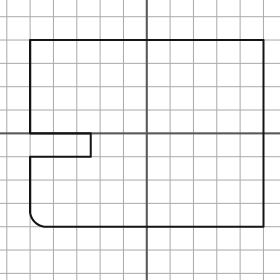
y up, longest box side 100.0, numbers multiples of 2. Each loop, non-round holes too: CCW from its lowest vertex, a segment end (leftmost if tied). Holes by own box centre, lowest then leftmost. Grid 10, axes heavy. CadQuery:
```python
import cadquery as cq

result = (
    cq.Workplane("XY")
    .moveTo(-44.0, -40.0)
    .lineTo(50.0, -40.0)
    .lineTo(50.0, 40.0)
    .lineTo(-50.0, 40.0)
    .lineTo(-50.0, 0.0)
    .lineTo(-24.0, 0.0)
    .lineTo(-24.0, -10.0)
    .lineTo(-50.0, -10.0)
    .lineTo(-50.0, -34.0)
    .threePointArc((-48.0, -38.0), (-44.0, -40.0))
    .close()
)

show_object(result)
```